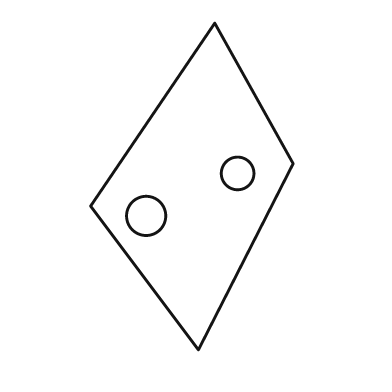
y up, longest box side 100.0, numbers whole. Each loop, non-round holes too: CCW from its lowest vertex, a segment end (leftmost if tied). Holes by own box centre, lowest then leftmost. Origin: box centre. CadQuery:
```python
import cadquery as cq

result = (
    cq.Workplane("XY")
    .moveTo(2.0, -50.0)
    .lineTo(31.0, 7.0)
    .lineTo(7.0, 50.0)
    .lineTo(-31.0, -6.0)
    .close()
    .moveTo(-14.0, -9.0)
    .circle(6.0)
    .moveTo(14.0, 4.0)
    .circle(5.0)
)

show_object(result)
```